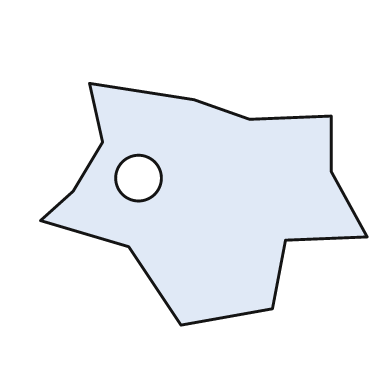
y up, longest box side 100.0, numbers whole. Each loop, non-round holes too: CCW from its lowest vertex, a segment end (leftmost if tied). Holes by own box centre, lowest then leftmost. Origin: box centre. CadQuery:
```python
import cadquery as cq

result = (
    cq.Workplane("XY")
    .moveTo(-7.0, -37.0)
    .lineTo(21.0, -32.0)
    .lineTo(25.0, -11.0)
    .lineTo(50.0, -10.0)
    .lineTo(39.0, 10.0)
    .lineTo(39.0, 27.0)
    .lineTo(14.0, 26.0)
    .lineTo(-3.0, 32.0)
    .lineTo(-35.0, 37.0)
    .lineTo(-31.0, 19.0)
    .lineTo(-40.0, 4.0)
    .lineTo(-50.0, -5.0)
    .lineTo(-23.0, -13.0)
    .close()
    .moveTo(-20.0, 8.0)
    .circle(7.0)
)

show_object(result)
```